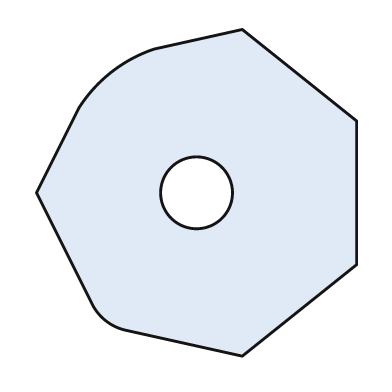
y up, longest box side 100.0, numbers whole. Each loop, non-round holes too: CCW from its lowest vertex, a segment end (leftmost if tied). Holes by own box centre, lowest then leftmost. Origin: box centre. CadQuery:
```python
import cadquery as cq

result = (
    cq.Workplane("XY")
    .moveTo(14.0, -50.0)
    .lineTo(49.0, -22.0)
    .lineTo(49.0, 22.0)
    .lineTo(14.0, 50.0)
    .lineTo(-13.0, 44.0)
    .threePointArc((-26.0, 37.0), (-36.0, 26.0))
    .lineTo(-49.0, 0.0)
    .lineTo(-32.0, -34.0)
    .threePointArc((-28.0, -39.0), (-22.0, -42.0))
    .close()
    .moveTo(0.0, 0.0)
    .circle(11.0)
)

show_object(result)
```